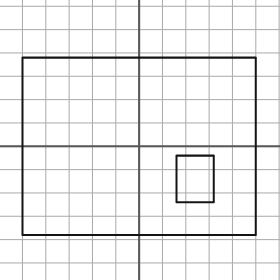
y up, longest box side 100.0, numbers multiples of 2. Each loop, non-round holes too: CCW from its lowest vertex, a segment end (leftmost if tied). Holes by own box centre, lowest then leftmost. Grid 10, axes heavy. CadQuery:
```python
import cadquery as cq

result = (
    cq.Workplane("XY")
    .moveTo(-50.0, -38.0)
    .lineTo(50.0, -38.0)
    .lineTo(50.0, 38.0)
    .lineTo(-50.0, 38.0)
    .close()
    .moveTo(16.0, -24.0)
    .lineTo(32.0, -24.0)
    .lineTo(32.0, -4.0)
    .lineTo(16.0, -4.0)
    .close()
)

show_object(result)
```